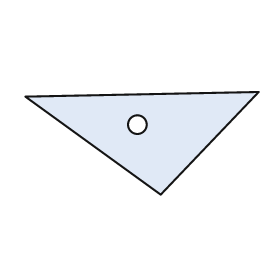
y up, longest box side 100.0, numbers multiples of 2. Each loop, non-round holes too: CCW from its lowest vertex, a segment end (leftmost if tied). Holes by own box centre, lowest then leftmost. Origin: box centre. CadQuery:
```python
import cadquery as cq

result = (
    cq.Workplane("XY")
    .moveTo(8.0, -22.0)
    .lineTo(50.0, 22.0)
    .lineTo(-50.0, 20.0)
    .close()
    .moveTo(-2.0, 8.0)
    .circle(4.0)
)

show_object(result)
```